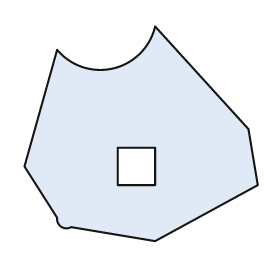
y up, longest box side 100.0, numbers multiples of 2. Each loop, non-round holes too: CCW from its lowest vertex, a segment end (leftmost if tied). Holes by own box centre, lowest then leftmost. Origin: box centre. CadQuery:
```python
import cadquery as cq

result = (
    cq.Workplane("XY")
    .moveTo(6.0, -46.0)
    .lineTo(50.0, -22.0)
    .lineTo(46.0, 2.0)
    .lineTo(6.0, 46.0)
    .threePointArc((-12.0, 28.0), (-36.0, 36.0))
    .lineTo(-50.0, -14.0)
    .lineTo(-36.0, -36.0)
    .threePointArc((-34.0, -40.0), (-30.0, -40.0))
    .close()
    .moveTo(-10.0, -22.0)
    .lineTo(6.0, -22.0)
    .lineTo(6.0, -6.0)
    .lineTo(-10.0, -6.0)
    .close()
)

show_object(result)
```